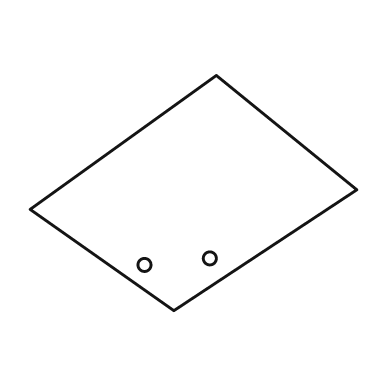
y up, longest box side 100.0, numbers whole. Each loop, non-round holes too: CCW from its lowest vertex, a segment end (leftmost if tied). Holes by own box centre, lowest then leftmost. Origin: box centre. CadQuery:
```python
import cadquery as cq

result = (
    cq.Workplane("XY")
    .moveTo(-6.0, -36.0)
    .lineTo(50.0, 1.0)
    .lineTo(7.0, 36.0)
    .lineTo(-50.0, -5.0)
    .close()
    .moveTo(-15.0, -22.0)
    .circle(2.0)
    .moveTo(5.0, -20.0)
    .circle(2.0)
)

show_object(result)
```